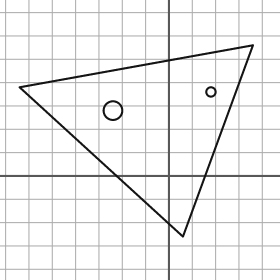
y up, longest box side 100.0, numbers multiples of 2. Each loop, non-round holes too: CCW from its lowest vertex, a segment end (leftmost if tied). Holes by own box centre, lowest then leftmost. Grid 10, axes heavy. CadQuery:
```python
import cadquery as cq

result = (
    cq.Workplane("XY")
    .moveTo(6.0, -26.0)
    .lineTo(36.0, 56.0)
    .lineTo(-64.0, 38.0)
    .close()
    .moveTo(-24.0, 28.0)
    .circle(4.0)
    .moveTo(18.0, 36.0)
    .circle(2.0)
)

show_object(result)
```